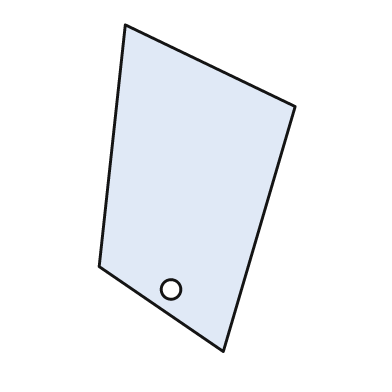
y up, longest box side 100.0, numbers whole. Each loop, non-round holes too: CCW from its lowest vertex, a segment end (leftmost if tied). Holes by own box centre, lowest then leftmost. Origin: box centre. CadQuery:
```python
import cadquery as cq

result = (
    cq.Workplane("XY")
    .moveTo(8.0, -50.0)
    .lineTo(30.0, 25.0)
    .lineTo(-22.0, 50.0)
    .lineTo(-30.0, -24.0)
    .close()
    .moveTo(-8.0, -31.0)
    .circle(3.0)
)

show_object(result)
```